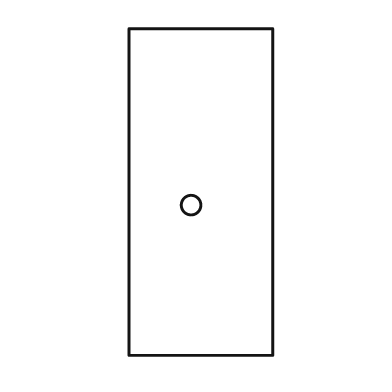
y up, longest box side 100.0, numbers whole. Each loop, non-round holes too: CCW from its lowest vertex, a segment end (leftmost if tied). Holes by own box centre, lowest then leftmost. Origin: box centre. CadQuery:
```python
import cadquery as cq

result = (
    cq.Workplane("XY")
    .moveTo(-22.0, -50.0)
    .lineTo(22.0, -50.0)
    .lineTo(22.0, 50.0)
    .lineTo(-22.0, 50.0)
    .close()
    .moveTo(-3.0, -4.0)
    .circle(3.0)
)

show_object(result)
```